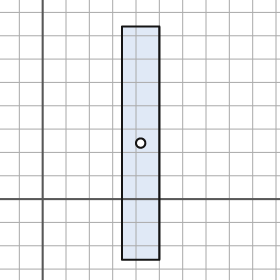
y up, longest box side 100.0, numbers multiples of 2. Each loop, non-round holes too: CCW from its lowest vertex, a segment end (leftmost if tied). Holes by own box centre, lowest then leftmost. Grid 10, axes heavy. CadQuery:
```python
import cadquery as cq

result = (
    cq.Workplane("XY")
    .moveTo(34.0, -26.0)
    .lineTo(50.0, -26.0)
    .lineTo(50.0, 74.0)
    .lineTo(34.0, 74.0)
    .close()
    .moveTo(42.0, 24.0)
    .circle(2.0)
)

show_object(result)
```